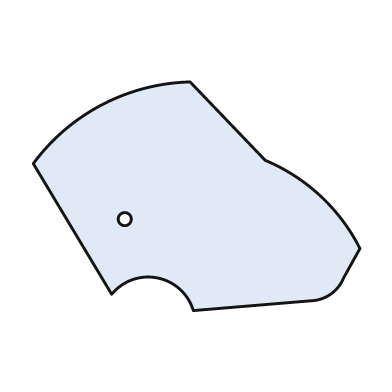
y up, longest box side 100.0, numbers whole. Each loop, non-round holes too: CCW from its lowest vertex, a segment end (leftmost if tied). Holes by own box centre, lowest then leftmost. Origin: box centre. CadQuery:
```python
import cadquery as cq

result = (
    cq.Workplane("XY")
    .moveTo(-1.0, -35.0)
    .lineTo(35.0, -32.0)
    .threePointArc((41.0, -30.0), (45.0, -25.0))
    .lineTo(50.0, -16.0)
    .threePointArc((38.0, 0.0), (21.0, 11.0))
    .lineTo(-2.0, 35.0)
    .threePointArc((-29.0, 28.0), (-50.0, 10.0))
    .lineTo(-26.0, -30.0)
    .threePointArc((-12.0, -25.0), (-1.0, -35.0))
    .close()
    .moveTo(-22.0, -7.0)
    .circle(2.0)
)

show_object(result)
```